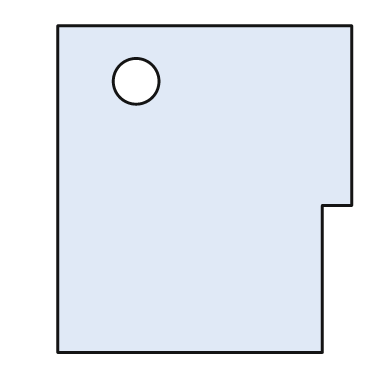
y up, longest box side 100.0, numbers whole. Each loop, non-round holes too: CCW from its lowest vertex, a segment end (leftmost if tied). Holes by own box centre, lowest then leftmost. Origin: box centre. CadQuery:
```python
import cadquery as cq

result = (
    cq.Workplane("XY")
    .moveTo(-45.0, -50.0)
    .lineTo(36.0, -50.0)
    .lineTo(36.0, -5.0)
    .lineTo(45.0, -5.0)
    .lineTo(45.0, 50.0)
    .lineTo(-45.0, 50.0)
    .close()
    .moveTo(-21.0, 33.0)
    .circle(7.0)
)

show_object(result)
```